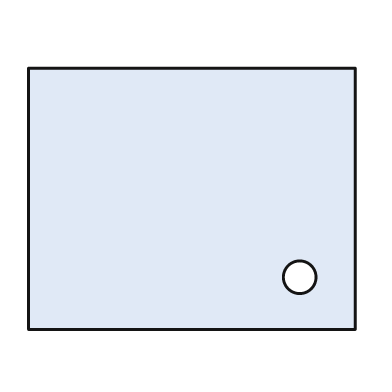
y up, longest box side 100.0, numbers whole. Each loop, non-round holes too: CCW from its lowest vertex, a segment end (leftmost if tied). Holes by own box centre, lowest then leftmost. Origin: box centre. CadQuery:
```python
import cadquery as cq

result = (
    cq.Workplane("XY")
    .moveTo(-50.0, -40.0)
    .lineTo(50.0, -40.0)
    .lineTo(50.0, 40.0)
    .lineTo(-50.0, 40.0)
    .close()
    .moveTo(33.0, -24.0)
    .circle(5.0)
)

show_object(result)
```